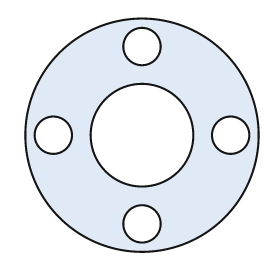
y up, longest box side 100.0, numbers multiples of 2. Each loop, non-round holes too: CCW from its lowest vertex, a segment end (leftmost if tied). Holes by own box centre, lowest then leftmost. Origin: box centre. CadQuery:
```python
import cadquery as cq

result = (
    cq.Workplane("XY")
    .moveTo(0.0, 0.0)
    .circle(50.0)
    .moveTo(0.0, -38.0)
    .circle(8.0)
    .moveTo(-38.0, 0.0)
    .circle(8.0)
    .moveTo(0.0, 0.0)
    .circle(22.0)
    .moveTo(38.0, 0.0)
    .circle(8.0)
    .moveTo(0.0, 38.0)
    .circle(8.0)
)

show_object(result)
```